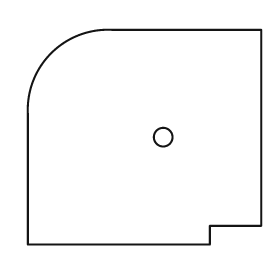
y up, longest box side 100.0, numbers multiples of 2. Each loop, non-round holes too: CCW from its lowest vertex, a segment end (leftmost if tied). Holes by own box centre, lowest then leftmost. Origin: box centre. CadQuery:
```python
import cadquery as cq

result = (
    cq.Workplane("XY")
    .moveTo(-50.0, -46.0)
    .lineTo(28.0, -46.0)
    .lineTo(28.0, -38.0)
    .lineTo(50.0, -38.0)
    .lineTo(50.0, 46.0)
    .lineTo(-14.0, 46.0)
    .threePointArc((-40.0, 36.0), (-50.0, 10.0))
    .close()
    .moveTo(8.0, 0.0)
    .circle(4.0)
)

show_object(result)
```